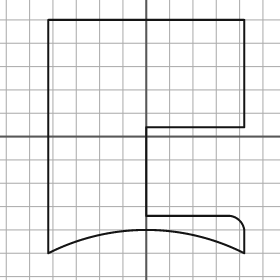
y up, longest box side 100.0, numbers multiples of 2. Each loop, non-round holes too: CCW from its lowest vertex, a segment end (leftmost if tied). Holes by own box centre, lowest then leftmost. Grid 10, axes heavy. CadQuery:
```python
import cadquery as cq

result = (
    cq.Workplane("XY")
    .moveTo(-42.0, -50.0)
    .threePointArc((0.0, -40.0), (42.0, -50.0))
    .lineTo(42.0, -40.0)
    .threePointArc((40.0, -36.0), (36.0, -34.0))
    .lineTo(0.0, -34.0)
    .lineTo(0.0, 4.0)
    .lineTo(42.0, 4.0)
    .lineTo(42.0, 50.0)
    .lineTo(-42.0, 50.0)
    .close()
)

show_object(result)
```